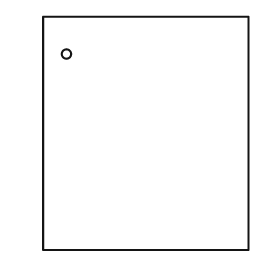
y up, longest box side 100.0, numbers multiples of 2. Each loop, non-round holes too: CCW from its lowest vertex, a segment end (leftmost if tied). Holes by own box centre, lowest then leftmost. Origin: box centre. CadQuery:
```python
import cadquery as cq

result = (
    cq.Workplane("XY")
    .moveTo(-44.0, -50.0)
    .lineTo(44.0, -50.0)
    .lineTo(44.0, 50.0)
    .lineTo(-44.0, 50.0)
    .close()
    .moveTo(-34.0, 34.0)
    .circle(2.0)
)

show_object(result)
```